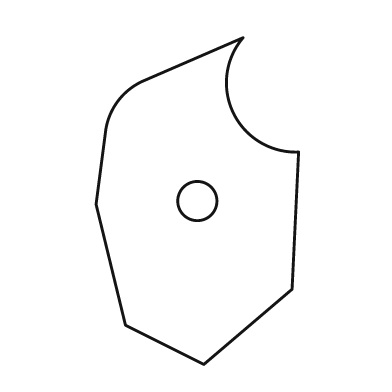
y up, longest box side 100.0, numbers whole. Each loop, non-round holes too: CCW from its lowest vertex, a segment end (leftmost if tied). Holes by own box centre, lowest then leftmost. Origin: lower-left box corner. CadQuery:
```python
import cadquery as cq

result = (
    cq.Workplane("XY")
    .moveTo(33.0, 0.0)
    .lineTo(60.0, 23.0)
    .lineTo(62.0, 65.0)
    .threePointArc((42.0, 77.0), (45.0, 100.0))
    .lineTo(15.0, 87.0)
    .threePointArc((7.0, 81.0), (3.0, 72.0))
    .lineTo(0.0, 49.0)
    .lineTo(9.0, 12.0)
    .close()
    .moveTo(31.0, 50.0)
    .circle(6.0)
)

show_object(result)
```